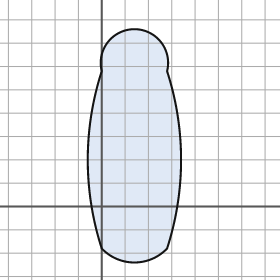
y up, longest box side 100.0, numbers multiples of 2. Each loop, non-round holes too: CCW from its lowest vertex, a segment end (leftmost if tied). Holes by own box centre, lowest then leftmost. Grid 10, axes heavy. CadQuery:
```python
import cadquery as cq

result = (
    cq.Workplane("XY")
    .moveTo(0.0, -18.0)
    .threePointArc((14.0, -24.0), (28.0, -18.0))
    .threePointArc((34.0, 20.0), (28.0, 58.0))
    .threePointArc((14.0, 76.0), (0.0, 58.0))
    .threePointArc((-6.0, 20.0), (0.0, -18.0))
    .close()
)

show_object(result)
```